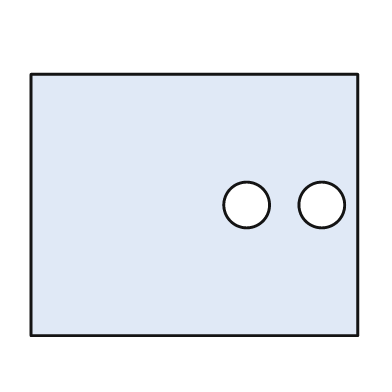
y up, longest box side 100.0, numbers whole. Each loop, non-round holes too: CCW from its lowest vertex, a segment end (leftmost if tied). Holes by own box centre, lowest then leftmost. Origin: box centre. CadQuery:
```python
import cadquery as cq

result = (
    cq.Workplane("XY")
    .moveTo(-50.0, -40.0)
    .lineTo(50.0, -40.0)
    .lineTo(50.0, 40.0)
    .lineTo(-50.0, 40.0)
    .close()
    .moveTo(16.0, 0.0)
    .circle(7.0)
    .moveTo(39.0, 0.0)
    .circle(7.0)
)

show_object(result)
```